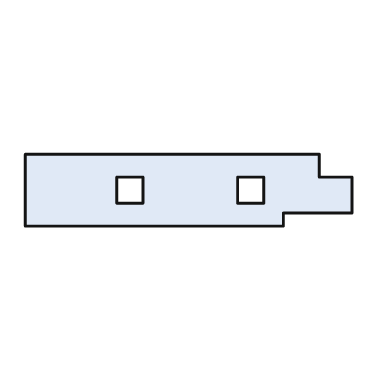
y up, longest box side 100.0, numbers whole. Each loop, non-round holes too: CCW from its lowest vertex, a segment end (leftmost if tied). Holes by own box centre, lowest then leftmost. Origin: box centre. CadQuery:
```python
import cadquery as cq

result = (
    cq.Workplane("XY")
    .moveTo(-50.0, -11.0)
    .lineTo(29.0, -11.0)
    .lineTo(29.0, -7.0)
    .lineTo(50.0, -7.0)
    .lineTo(50.0, 4.0)
    .lineTo(40.0, 4.0)
    .lineTo(40.0, 11.0)
    .lineTo(-50.0, 11.0)
    .close()
    .moveTo(-22.0, -4.0)
    .lineTo(-14.0, -4.0)
    .lineTo(-14.0, 4.0)
    .lineTo(-22.0, 4.0)
    .close()
    .moveTo(15.0, -4.0)
    .lineTo(23.0, -4.0)
    .lineTo(23.0, 4.0)
    .lineTo(15.0, 4.0)
    .close()
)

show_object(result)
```